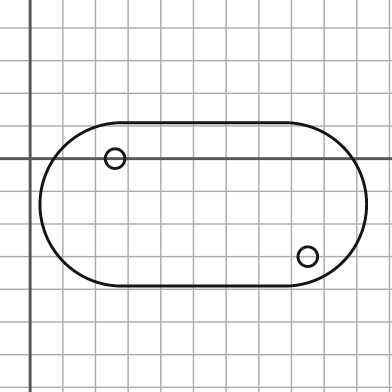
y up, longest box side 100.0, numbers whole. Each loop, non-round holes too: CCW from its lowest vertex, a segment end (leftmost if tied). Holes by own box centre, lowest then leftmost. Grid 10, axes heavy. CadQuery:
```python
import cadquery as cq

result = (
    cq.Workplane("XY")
    .moveTo(28.0, -39.0)
    .lineTo(78.0, -39.0)
    .threePointArc((103.0, -14.0), (78.0, 11.0))
    .lineTo(28.0, 11.0)
    .threePointArc((3.0, -14.0), (28.0, -39.0))
    .close()
    .moveTo(85.0, -30.0)
    .circle(3.0)
    .moveTo(26.0, 0.0)
    .circle(3.0)
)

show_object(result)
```